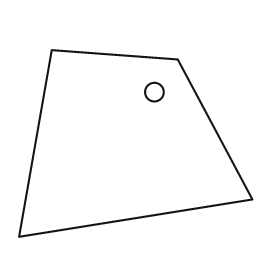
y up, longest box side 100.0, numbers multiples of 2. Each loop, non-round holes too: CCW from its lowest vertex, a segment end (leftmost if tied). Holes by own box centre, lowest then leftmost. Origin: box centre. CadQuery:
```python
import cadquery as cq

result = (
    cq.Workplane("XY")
    .moveTo(-50.0, -40.0)
    .lineTo(50.0, -24.0)
    .lineTo(18.0, 36.0)
    .lineTo(-36.0, 40.0)
    .close()
    .moveTo(8.0, 22.0)
    .circle(4.0)
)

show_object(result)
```